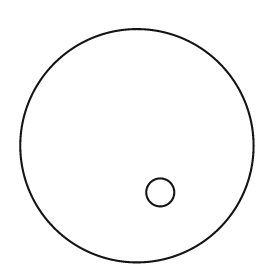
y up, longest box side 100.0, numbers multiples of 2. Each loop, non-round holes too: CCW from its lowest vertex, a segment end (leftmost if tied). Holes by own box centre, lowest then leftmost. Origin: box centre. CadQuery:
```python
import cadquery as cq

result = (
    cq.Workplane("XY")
    .moveTo(0.0, 0.0)
    .circle(50.0)
    .moveTo(10.0, -20.0)
    .circle(6.0)
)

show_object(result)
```